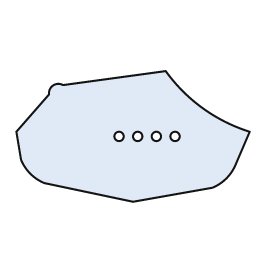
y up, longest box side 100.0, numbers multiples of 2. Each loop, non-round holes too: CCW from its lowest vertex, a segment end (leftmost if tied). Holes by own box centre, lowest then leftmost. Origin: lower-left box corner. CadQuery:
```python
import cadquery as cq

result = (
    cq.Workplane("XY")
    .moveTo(50.0, 0.0)
    .lineTo(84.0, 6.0)
    .threePointArc((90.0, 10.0), (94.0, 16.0))
    .lineTo(100.0, 30.0)
    .threePointArc((80.0, 40.0), (64.0, 56.0))
    .lineTo(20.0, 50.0)
    .threePointArc((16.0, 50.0), (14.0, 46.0))
    .lineTo(0.0, 30.0)
    .lineTo(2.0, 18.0)
    .threePointArc((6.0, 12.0), (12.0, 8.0))
    .close()
    .moveTo(44.0, 28.0)
    .circle(2.0)
    .moveTo(52.0, 28.0)
    .circle(2.0)
    .moveTo(60.0, 28.0)
    .circle(2.0)
    .moveTo(68.0, 28.0)
    .circle(2.0)
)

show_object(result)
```